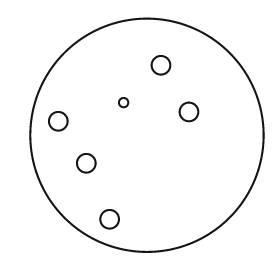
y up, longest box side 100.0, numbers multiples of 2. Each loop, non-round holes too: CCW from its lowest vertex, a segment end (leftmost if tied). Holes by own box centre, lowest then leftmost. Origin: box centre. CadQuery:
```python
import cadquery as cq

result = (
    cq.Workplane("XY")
    .moveTo(0.0, 0.0)
    .circle(50.0)
    .moveTo(-16.0, -36.0)
    .circle(4.0)
    .moveTo(-26.0, -12.0)
    .circle(4.0)
    .moveTo(-38.0, 6.0)
    .circle(4.0)
    .moveTo(18.0, 10.0)
    .circle(4.0)
    .moveTo(-10.0, 14.0)
    .circle(2.0)
    .moveTo(6.0, 30.0)
    .circle(4.0)
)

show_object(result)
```